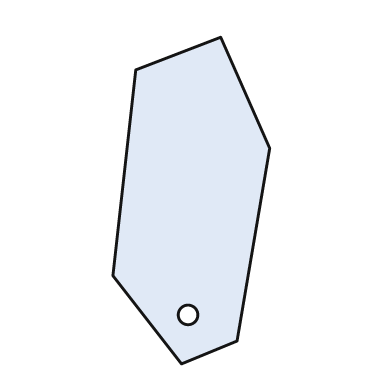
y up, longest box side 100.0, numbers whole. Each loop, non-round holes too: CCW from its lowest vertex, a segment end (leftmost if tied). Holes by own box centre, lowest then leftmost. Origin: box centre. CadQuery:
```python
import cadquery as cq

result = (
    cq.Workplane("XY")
    .moveTo(-3.0, -50.0)
    .lineTo(14.0, -43.0)
    .lineTo(24.0, 16.0)
    .lineTo(9.0, 50.0)
    .lineTo(-17.0, 40.0)
    .lineTo(-24.0, -23.0)
    .close()
    .moveTo(-1.0, -35.0)
    .circle(3.0)
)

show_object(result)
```